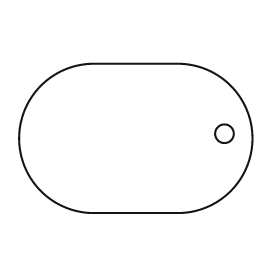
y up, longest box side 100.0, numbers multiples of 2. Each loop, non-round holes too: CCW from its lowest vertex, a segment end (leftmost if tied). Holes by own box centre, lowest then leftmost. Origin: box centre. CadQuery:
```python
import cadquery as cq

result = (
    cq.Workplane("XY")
    .moveTo(-18.0, -32.0)
    .lineTo(18.0, -32.0)
    .threePointArc((50.0, 0.0), (18.0, 32.0))
    .lineTo(-18.0, 32.0)
    .threePointArc((-50.0, 0.0), (-18.0, -32.0))
    .close()
    .moveTo(38.0, 2.0)
    .circle(4.0)
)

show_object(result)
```